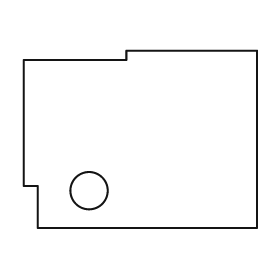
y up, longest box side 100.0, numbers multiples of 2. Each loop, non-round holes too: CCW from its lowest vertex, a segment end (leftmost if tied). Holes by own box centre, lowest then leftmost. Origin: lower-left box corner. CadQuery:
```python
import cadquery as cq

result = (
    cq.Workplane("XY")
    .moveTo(6.0, 0.0)
    .lineTo(100.0, 0.0)
    .lineTo(100.0, 76.0)
    .lineTo(44.0, 76.0)
    .lineTo(44.0, 72.0)
    .lineTo(0.0, 72.0)
    .lineTo(0.0, 18.0)
    .lineTo(6.0, 18.0)
    .close()
    .moveTo(28.0, 16.0)
    .circle(8.0)
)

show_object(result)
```